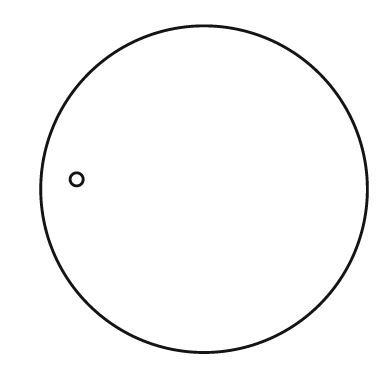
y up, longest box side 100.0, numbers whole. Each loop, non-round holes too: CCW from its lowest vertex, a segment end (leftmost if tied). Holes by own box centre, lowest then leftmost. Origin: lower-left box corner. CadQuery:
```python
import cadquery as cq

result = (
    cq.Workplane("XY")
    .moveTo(50.0, 50.0)
    .circle(50.0)
    .moveTo(11.0, 53.0)
    .circle(2.0)
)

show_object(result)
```